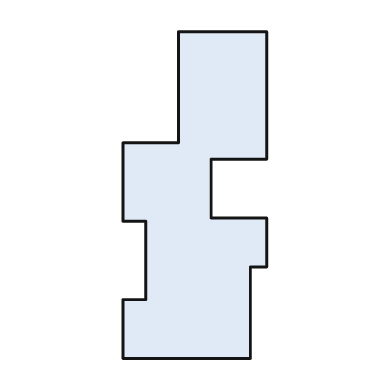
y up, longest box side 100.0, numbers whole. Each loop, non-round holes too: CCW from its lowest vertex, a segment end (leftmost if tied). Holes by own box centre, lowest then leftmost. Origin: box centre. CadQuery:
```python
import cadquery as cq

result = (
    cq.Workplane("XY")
    .moveTo(-22.0, -50.0)
    .lineTo(17.0, -50.0)
    .lineTo(17.0, -22.0)
    .lineTo(22.0, -22.0)
    .lineTo(22.0, -7.0)
    .lineTo(5.0, -7.0)
    .lineTo(5.0, 11.0)
    .lineTo(22.0, 11.0)
    .lineTo(22.0, 50.0)
    .lineTo(-5.0, 50.0)
    .lineTo(-5.0, 16.0)
    .lineTo(-22.0, 16.0)
    .lineTo(-22.0, -8.0)
    .lineTo(-15.0, -8.0)
    .lineTo(-15.0, -32.0)
    .lineTo(-22.0, -32.0)
    .close()
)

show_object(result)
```